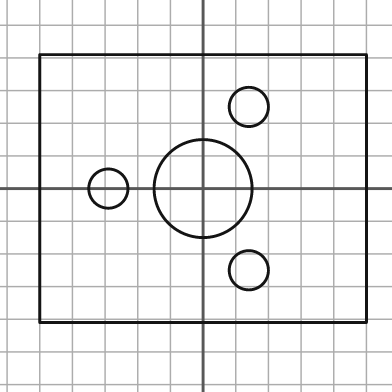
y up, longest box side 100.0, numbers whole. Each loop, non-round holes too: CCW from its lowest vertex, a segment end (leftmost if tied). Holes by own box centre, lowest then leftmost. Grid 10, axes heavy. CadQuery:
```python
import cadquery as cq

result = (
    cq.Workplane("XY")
    .moveTo(-50.0, -41.0)
    .lineTo(50.0, -41.0)
    .lineTo(50.0, 41.0)
    .lineTo(-50.0, 41.0)
    .close()
    .moveTo(14.0, -25.0)
    .circle(6.0)
    .moveTo(-29.0, 0.0)
    .circle(6.0)
    .moveTo(0.0, 0.0)
    .circle(15.0)
    .moveTo(14.0, 25.0)
    .circle(6.0)
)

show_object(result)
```